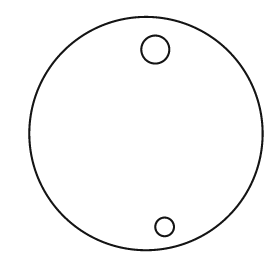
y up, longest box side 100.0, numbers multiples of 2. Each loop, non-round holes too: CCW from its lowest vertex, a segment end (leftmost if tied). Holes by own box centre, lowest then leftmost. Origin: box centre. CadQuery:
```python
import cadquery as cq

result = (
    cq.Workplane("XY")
    .moveTo(0.0, 0.0)
    .circle(50.0)
    .moveTo(8.0, -40.0)
    .circle(4.0)
    .moveTo(4.0, 36.0)
    .circle(6.0)
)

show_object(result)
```